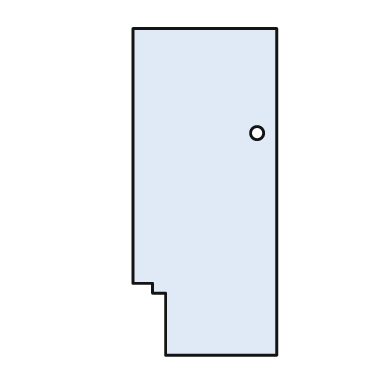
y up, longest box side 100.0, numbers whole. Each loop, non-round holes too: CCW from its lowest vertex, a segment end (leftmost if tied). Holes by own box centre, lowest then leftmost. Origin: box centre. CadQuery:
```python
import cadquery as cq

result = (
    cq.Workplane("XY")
    .moveTo(-12.0, -50.0)
    .lineTo(22.0, -50.0)
    .lineTo(22.0, 50.0)
    .lineTo(-22.0, 50.0)
    .lineTo(-22.0, -28.0)
    .lineTo(-16.0, -28.0)
    .lineTo(-16.0, -31.0)
    .lineTo(-12.0, -31.0)
    .close()
    .moveTo(16.0, 18.0)
    .circle(2.0)
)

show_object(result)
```